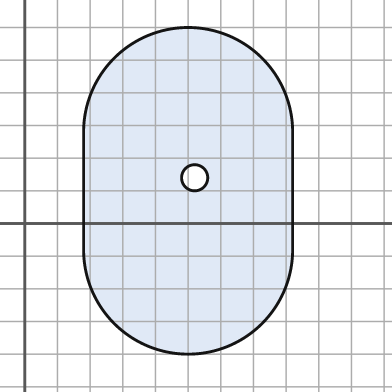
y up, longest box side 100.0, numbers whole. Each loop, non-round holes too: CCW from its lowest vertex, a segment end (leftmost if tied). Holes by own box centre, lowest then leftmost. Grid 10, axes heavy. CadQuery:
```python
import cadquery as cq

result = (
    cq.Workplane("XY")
    .moveTo(18.0, -8.0)
    .threePointArc((50.0, -40.0), (82.0, -8.0))
    .lineTo(82.0, 28.0)
    .threePointArc((50.0, 60.0), (18.0, 28.0))
    .close()
    .moveTo(52.0, 14.0)
    .circle(4.0)
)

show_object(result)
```